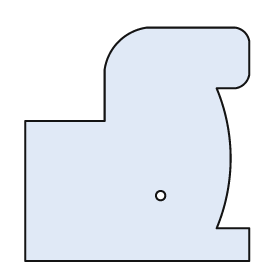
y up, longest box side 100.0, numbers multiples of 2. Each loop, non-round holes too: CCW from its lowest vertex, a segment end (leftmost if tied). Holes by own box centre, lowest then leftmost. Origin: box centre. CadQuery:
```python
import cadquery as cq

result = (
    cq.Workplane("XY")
    .moveTo(-48.0, -50.0)
    .lineTo(48.0, -50.0)
    .lineTo(48.0, -36.0)
    .lineTo(34.0, -36.0)
    .threePointArc((40.0, -6.0), (34.0, 24.0))
    .lineTo(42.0, 24.0)
    .threePointArc((46.0, 26.0), (48.0, 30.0))
    .lineTo(48.0, 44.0)
    .threePointArc((46.0, 48.0), (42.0, 50.0))
    .lineTo(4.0, 50.0)
    .threePointArc((-8.0, 44.0), (-14.0, 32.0))
    .lineTo(-14.0, 10.0)
    .lineTo(-48.0, 10.0)
    .close()
    .moveTo(10.0, -22.0)
    .circle(2.0)
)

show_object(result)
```